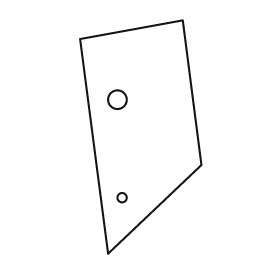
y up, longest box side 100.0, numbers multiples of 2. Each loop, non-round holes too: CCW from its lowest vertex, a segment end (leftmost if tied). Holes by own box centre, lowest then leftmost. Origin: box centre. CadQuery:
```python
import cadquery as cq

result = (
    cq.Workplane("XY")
    .moveTo(-14.0, -50.0)
    .lineTo(26.0, -12.0)
    .lineTo(18.0, 50.0)
    .lineTo(-26.0, 42.0)
    .close()
    .moveTo(-8.0, -26.0)
    .circle(2.0)
    .moveTo(-10.0, 16.0)
    .circle(4.0)
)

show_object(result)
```